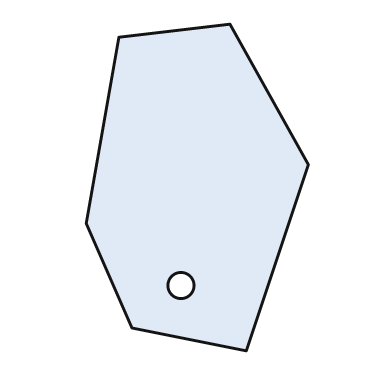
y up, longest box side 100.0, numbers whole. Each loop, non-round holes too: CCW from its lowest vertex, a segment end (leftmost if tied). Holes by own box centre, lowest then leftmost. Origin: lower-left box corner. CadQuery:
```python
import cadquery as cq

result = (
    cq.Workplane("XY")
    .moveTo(49.0, 0.0)
    .lineTo(68.0, 57.0)
    .lineTo(44.0, 100.0)
    .lineTo(10.0, 96.0)
    .lineTo(0.0, 39.0)
    .lineTo(14.0, 7.0)
    .close()
    .moveTo(29.0, 20.0)
    .circle(4.0)
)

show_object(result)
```